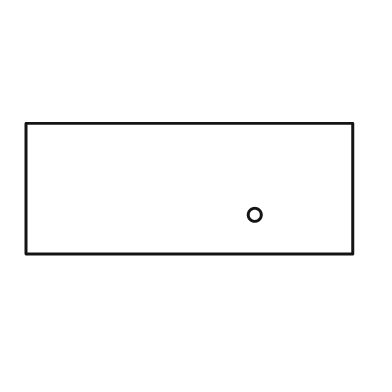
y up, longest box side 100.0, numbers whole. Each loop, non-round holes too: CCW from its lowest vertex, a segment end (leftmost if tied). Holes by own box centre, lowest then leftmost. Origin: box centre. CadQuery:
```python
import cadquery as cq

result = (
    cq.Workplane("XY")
    .moveTo(-50.0, -20.0)
    .lineTo(50.0, -20.0)
    .lineTo(50.0, 20.0)
    .lineTo(-50.0, 20.0)
    .close()
    .moveTo(20.0, -8.0)
    .circle(2.0)
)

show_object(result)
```